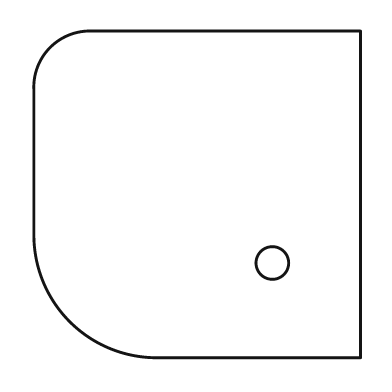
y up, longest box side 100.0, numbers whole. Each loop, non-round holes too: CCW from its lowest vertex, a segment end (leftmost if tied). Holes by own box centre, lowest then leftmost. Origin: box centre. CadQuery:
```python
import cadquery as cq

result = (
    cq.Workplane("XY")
    .moveTo(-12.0, -50.0)
    .lineTo(50.0, -50.0)
    .lineTo(50.0, 50.0)
    .lineTo(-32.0, 50.0)
    .threePointArc((-45.0, 45.0), (-50.0, 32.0))
    .lineTo(-50.0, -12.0)
    .threePointArc((-39.0, -39.0), (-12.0, -50.0))
    .close()
    .moveTo(23.0, -21.0)
    .circle(5.0)
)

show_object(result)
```